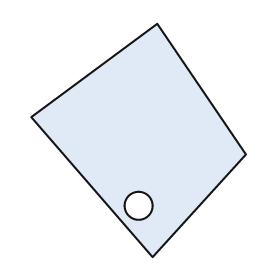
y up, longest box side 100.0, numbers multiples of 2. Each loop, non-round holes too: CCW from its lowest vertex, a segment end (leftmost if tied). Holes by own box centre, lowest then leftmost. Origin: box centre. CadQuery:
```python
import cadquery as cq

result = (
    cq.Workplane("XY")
    .moveTo(6.0, -50.0)
    .lineTo(46.0, -6.0)
    .lineTo(8.0, 50.0)
    .lineTo(-46.0, 10.0)
    .close()
    .moveTo(0.0, -28.0)
    .circle(6.0)
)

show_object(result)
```